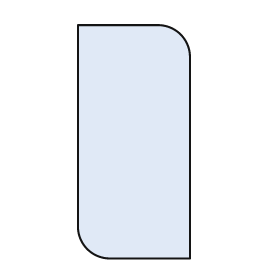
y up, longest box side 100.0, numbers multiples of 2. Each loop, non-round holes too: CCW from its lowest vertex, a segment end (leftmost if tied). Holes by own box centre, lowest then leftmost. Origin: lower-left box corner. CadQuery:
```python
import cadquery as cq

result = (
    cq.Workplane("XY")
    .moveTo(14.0, 0.0)
    .lineTo(48.0, 0.0)
    .lineTo(48.0, 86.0)
    .threePointArc((44.0, 96.0), (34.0, 100.0))
    .lineTo(0.0, 100.0)
    .lineTo(0.0, 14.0)
    .threePointArc((4.0, 4.0), (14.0, 0.0))
    .close()
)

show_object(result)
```